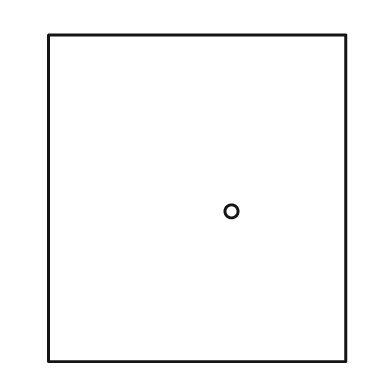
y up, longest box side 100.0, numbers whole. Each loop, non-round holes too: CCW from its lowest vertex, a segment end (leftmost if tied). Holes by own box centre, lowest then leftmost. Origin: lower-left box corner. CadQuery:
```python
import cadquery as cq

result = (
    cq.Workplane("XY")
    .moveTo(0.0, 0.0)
    .lineTo(91.0, 0.0)
    .lineTo(91.0, 100.0)
    .lineTo(0.0, 100.0)
    .close()
    .moveTo(56.0, 46.0)
    .circle(2.0)
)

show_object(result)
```